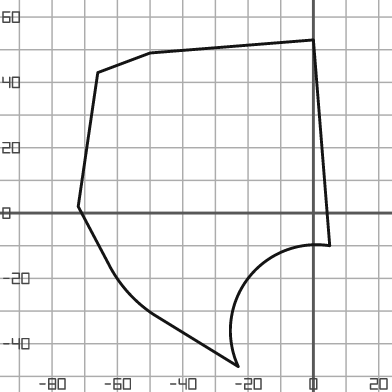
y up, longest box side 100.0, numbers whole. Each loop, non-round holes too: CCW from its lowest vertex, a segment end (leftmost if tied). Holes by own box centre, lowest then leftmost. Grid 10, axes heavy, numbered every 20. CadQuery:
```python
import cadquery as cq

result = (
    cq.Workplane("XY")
    .moveTo(-23.0, -47.0)
    .threePointArc((-20.0, -20.0), (5.0, -10.0))
    .lineTo(0.0, 53.0)
    .lineTo(-50.0, 49.0)
    .lineTo(-66.0, 43.0)
    .lineTo(-72.0, 2.0)
    .lineTo(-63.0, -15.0)
    .threePointArc((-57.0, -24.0), (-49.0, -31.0))
    .close()
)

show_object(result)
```